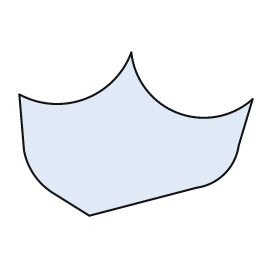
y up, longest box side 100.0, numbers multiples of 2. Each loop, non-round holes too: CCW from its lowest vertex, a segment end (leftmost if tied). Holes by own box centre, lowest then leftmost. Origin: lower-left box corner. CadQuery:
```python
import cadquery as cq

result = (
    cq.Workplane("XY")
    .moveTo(30.0, 0.0)
    .lineTo(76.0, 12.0)
    .threePointArc((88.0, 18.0), (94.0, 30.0))
    .lineTo(100.0, 50.0)
    .threePointArc((68.0, 44.0), (48.0, 70.0))
    .threePointArc((28.0, 50.0), (0.0, 52.0))
    .lineTo(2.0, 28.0)
    .threePointArc((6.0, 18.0), (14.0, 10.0))
    .close()
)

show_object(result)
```